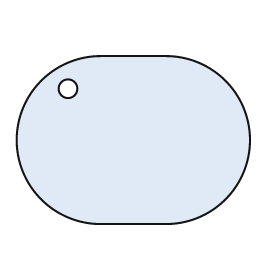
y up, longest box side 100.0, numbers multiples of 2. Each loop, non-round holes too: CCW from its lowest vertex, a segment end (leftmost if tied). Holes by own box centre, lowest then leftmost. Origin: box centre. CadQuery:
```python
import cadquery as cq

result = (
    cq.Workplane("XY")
    .moveTo(-14.0, -36.0)
    .lineTo(14.0, -36.0)
    .threePointArc((50.0, 0.0), (14.0, 36.0))
    .lineTo(-14.0, 36.0)
    .threePointArc((-50.0, 0.0), (-14.0, -36.0))
    .close()
    .moveTo(-28.0, 22.0)
    .circle(4.0)
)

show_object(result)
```